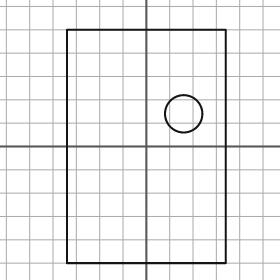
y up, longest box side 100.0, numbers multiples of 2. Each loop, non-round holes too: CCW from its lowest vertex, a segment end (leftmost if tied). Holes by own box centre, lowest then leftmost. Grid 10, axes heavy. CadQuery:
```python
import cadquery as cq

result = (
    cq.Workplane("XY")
    .moveTo(-34.0, -50.0)
    .lineTo(34.0, -50.0)
    .lineTo(34.0, 50.0)
    .lineTo(-34.0, 50.0)
    .close()
    .moveTo(16.0, 14.0)
    .circle(8.0)
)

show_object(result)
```